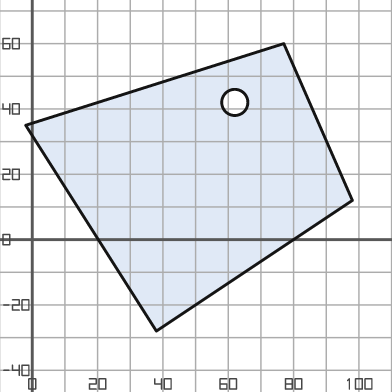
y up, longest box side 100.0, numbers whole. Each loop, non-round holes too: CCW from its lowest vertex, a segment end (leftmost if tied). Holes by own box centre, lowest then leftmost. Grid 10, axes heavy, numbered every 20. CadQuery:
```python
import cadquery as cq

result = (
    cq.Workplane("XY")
    .moveTo(38.0, -28.0)
    .lineTo(98.0, 12.0)
    .lineTo(77.0, 60.0)
    .lineTo(-2.0, 35.0)
    .close()
    .moveTo(62.0, 42.0)
    .circle(4.0)
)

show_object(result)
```